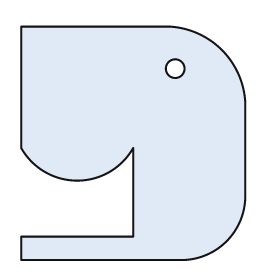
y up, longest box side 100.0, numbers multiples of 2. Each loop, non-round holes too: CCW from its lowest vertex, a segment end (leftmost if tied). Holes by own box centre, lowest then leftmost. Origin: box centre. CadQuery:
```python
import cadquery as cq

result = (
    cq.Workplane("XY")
    .moveTo(-48.0, -50.0)
    .lineTo(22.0, -50.0)
    .threePointArc((40.0, -42.0), (48.0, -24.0))
    .lineTo(48.0, 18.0)
    .threePointArc((38.0, 40.0), (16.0, 50.0))
    .lineTo(-48.0, 50.0)
    .lineTo(-48.0, -2.0)
    .threePointArc((-24.0, -16.0), (0.0, -2.0))
    .lineTo(0.0, -40.0)
    .lineTo(-48.0, -40.0)
    .close()
    .moveTo(18.0, 32.0)
    .circle(4.0)
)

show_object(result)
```